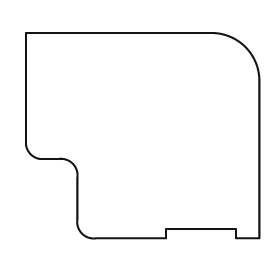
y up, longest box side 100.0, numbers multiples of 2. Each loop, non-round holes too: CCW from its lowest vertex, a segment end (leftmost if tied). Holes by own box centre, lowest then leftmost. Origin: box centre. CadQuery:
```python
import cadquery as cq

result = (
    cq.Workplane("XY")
    .moveTo(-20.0, -44.0)
    .lineTo(10.0, -44.0)
    .lineTo(10.0, -40.0)
    .lineTo(40.0, -40.0)
    .lineTo(40.0, -44.0)
    .lineTo(50.0, -44.0)
    .lineTo(50.0, 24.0)
    .threePointArc((44.0, 38.0), (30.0, 44.0))
    .lineTo(-50.0, 44.0)
    .lineTo(-50.0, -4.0)
    .threePointArc((-48.0, -8.0), (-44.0, -10.0))
    .lineTo(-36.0, -10.0)
    .threePointArc((-30.0, -12.0), (-28.0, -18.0))
    .lineTo(-28.0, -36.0)
    .threePointArc((-26.0, -42.0), (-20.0, -44.0))
    .close()
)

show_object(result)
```